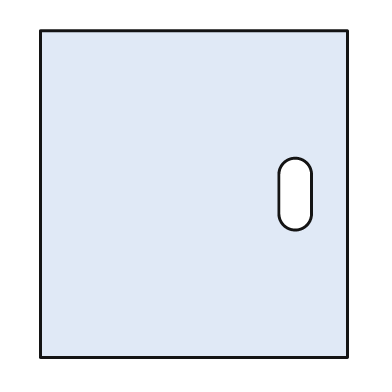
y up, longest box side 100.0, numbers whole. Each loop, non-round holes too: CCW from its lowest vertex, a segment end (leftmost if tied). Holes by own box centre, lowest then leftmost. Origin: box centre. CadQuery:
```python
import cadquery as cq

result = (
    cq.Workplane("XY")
    .moveTo(-47.0, -50.0)
    .lineTo(47.0, -50.0)
    .lineTo(47.0, 50.0)
    .lineTo(-47.0, 50.0)
    .close()
    .moveTo(26.0, -6.0)
    .threePointArc((31.0, -11.0), (36.0, -6.0))
    .lineTo(36.0, 6.0)
    .threePointArc((31.0, 11.0), (26.0, 6.0))
    .close()
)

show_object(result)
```